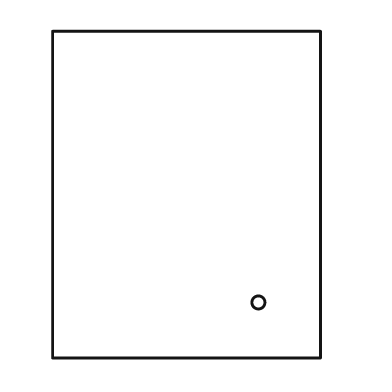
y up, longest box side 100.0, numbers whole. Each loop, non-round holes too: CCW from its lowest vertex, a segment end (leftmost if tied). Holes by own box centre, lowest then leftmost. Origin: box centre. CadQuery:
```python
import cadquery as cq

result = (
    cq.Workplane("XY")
    .moveTo(-41.0, -50.0)
    .lineTo(41.0, -50.0)
    .lineTo(41.0, 50.0)
    .lineTo(-41.0, 50.0)
    .close()
    .moveTo(22.0, -33.0)
    .circle(2.0)
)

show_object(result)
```